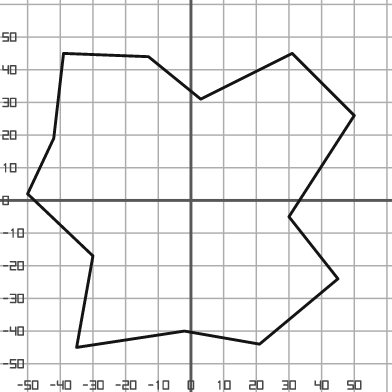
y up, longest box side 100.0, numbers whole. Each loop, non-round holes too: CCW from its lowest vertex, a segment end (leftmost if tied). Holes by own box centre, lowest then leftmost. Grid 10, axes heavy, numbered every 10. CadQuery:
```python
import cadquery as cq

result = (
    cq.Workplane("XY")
    .moveTo(-35.0, -45.0)
    .lineTo(-2.0, -40.0)
    .lineTo(21.0, -44.0)
    .lineTo(45.0, -24.0)
    .lineTo(30.0, -5.0)
    .lineTo(50.0, 26.0)
    .lineTo(31.0, 45.0)
    .lineTo(3.0, 31.0)
    .lineTo(-13.0, 44.0)
    .lineTo(-39.0, 45.0)
    .lineTo(-42.0, 19.0)
    .lineTo(-50.0, 2.0)
    .lineTo(-30.0, -17.0)
    .close()
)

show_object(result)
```